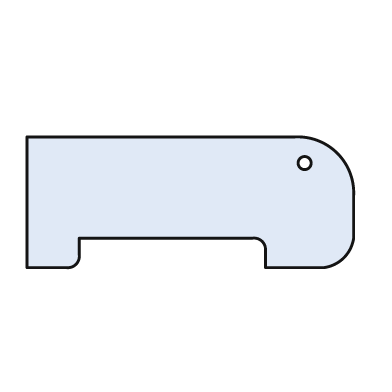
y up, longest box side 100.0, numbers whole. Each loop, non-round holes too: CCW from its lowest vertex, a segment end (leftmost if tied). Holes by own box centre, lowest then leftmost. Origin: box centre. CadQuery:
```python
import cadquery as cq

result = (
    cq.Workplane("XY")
    .moveTo(-50.0, -20.0)
    .lineTo(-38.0, -20.0)
    .threePointArc((-35.0, -19.0), (-34.0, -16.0))
    .lineTo(-34.0, -11.0)
    .lineTo(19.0, -11.0)
    .threePointArc((22.0, -12.0), (23.0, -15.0))
    .lineTo(23.0, -20.0)
    .lineTo(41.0, -20.0)
    .threePointArc((47.0, -17.0), (50.0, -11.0))
    .lineTo(50.0, 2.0)
    .threePointArc((45.0, 15.0), (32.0, 20.0))
    .lineTo(-50.0, 20.0)
    .close()
    .moveTo(35.0, 12.0)
    .circle(2.0)
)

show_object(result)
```